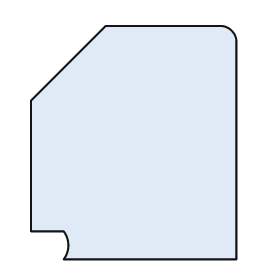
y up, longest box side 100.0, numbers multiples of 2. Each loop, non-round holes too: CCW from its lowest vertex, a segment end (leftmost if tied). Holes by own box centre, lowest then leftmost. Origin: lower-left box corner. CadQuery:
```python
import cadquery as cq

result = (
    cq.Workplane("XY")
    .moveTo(14.0, 0.0)
    .lineTo(88.0, 0.0)
    .lineTo(88.0, 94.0)
    .threePointArc((86.0, 98.0), (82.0, 100.0))
    .lineTo(32.0, 100.0)
    .lineTo(0.0, 68.0)
    .lineTo(0.0, 12.0)
    .lineTo(14.0, 12.0)
    .threePointArc((16.0, 6.0), (14.0, 0.0))
    .close()
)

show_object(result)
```